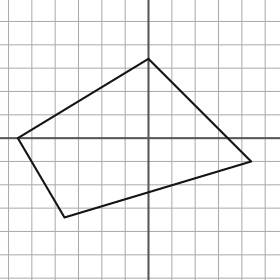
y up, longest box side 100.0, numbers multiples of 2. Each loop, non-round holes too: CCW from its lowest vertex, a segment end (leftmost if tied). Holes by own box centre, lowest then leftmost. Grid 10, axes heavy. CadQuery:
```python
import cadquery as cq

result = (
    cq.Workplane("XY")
    .moveTo(-36.0, -34.0)
    .lineTo(44.0, -10.0)
    .lineTo(0.0, 34.0)
    .lineTo(-56.0, 0.0)
    .close()
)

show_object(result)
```